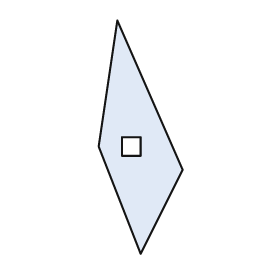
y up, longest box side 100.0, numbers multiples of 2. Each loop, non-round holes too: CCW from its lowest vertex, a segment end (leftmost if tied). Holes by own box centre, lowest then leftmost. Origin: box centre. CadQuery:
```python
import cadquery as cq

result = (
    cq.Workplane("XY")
    .moveTo(0.0, -50.0)
    .lineTo(18.0, -14.0)
    .lineTo(-10.0, 50.0)
    .lineTo(-18.0, -4.0)
    .close()
    .moveTo(-8.0, -8.0)
    .lineTo(0.0, -8.0)
    .lineTo(0.0, 0.0)
    .lineTo(-8.0, 0.0)
    .close()
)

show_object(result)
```